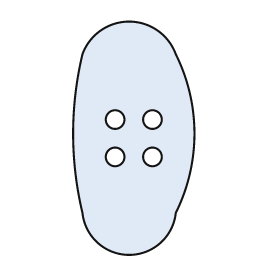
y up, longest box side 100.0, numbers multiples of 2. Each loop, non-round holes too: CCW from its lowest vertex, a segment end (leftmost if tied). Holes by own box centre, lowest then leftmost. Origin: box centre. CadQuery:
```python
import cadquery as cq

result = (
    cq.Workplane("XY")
    .moveTo(-22.0, -32.0)
    .threePointArc((-2.0, -50.0), (18.0, -32.0))
    .threePointArc((26.0, 2.0), (18.0, 36.0))
    .threePointArc((-2.0, 50.0), (-22.0, 36.0))
    .threePointArc((-26.0, 2.0), (-22.0, -32.0))
    .close()
    .moveTo(-8.0, -8.0)
    .circle(4.0)
    .moveTo(8.0, -8.0)
    .circle(4.0)
    .moveTo(-8.0, 8.0)
    .circle(4.0)
    .moveTo(8.0, 8.0)
    .circle(4.0)
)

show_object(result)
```